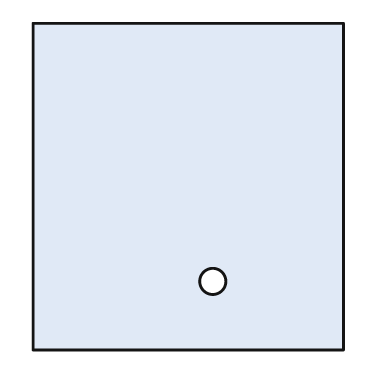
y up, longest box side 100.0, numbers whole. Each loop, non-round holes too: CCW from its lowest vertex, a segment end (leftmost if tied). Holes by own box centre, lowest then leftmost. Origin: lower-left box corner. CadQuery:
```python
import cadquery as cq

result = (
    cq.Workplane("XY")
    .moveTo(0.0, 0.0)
    .lineTo(95.0, 0.0)
    .lineTo(95.0, 100.0)
    .lineTo(0.0, 100.0)
    .close()
    .moveTo(55.0, 21.0)
    .circle(4.0)
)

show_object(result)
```